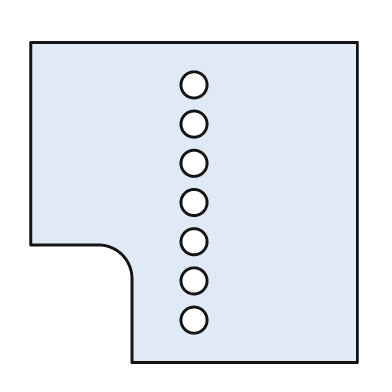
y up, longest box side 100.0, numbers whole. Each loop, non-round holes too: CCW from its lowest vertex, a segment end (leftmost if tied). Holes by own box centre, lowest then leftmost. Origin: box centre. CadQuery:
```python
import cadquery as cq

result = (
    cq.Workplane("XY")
    .moveTo(-19.0, -49.0)
    .lineTo(50.0, -49.0)
    .lineTo(50.0, 49.0)
    .lineTo(-50.0, 49.0)
    .lineTo(-50.0, -13.0)
    .lineTo(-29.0, -13.0)
    .threePointArc((-22.0, -16.0), (-19.0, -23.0))
    .close()
    .moveTo(0.0, -36.0)
    .circle(4.0)
    .moveTo(0.0, -24.0)
    .circle(4.0)
    .moveTo(0.0, -12.0)
    .circle(4.0)
    .moveTo(0.0, 0.0)
    .circle(4.0)
    .moveTo(0.0, 12.0)
    .circle(4.0)
    .moveTo(0.0, 24.0)
    .circle(4.0)
    .moveTo(0.0, 36.0)
    .circle(4.0)
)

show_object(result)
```